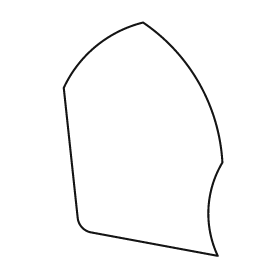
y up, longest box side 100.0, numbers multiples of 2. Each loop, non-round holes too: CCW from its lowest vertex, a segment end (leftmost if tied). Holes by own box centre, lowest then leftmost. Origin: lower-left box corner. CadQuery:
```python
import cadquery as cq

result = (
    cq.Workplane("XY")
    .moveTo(66.0, 0.0)
    .threePointArc((62.0, 20.0), (68.0, 40.0))
    .threePointArc((58.0, 74.0), (34.0, 100.0))
    .threePointArc((14.0, 90.0), (0.0, 72.0))
    .lineTo(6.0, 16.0)
    .threePointArc((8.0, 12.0), (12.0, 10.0))
    .close()
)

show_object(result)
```